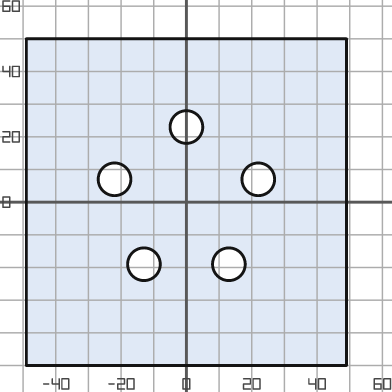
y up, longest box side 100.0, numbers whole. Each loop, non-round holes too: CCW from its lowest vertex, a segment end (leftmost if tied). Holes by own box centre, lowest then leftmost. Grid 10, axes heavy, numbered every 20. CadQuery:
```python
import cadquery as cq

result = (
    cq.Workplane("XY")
    .moveTo(-49.0, -50.0)
    .lineTo(49.0, -50.0)
    .lineTo(49.0, 50.0)
    .lineTo(-49.0, 50.0)
    .close()
    .moveTo(-13.0, -19.0)
    .circle(5.0)
    .moveTo(13.0, -19.0)
    .circle(5.0)
    .moveTo(-22.0, 7.0)
    .circle(5.0)
    .moveTo(22.0, 7.0)
    .circle(5.0)
    .moveTo(0.0, 23.0)
    .circle(5.0)
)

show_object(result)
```